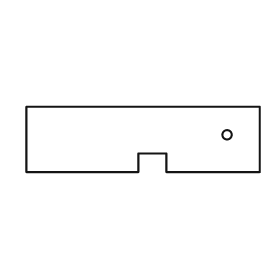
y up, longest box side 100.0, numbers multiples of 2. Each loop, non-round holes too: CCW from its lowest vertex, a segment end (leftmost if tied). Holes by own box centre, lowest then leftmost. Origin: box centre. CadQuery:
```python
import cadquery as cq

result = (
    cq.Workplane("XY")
    .moveTo(-50.0, -14.0)
    .lineTo(-2.0, -14.0)
    .lineTo(-2.0, -6.0)
    .lineTo(10.0, -6.0)
    .lineTo(10.0, -14.0)
    .lineTo(50.0, -14.0)
    .lineTo(50.0, 14.0)
    .lineTo(-50.0, 14.0)
    .close()
    .moveTo(36.0, 2.0)
    .circle(2.0)
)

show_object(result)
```